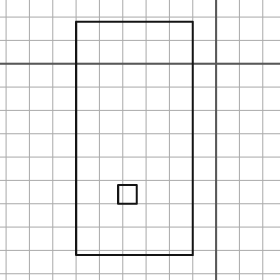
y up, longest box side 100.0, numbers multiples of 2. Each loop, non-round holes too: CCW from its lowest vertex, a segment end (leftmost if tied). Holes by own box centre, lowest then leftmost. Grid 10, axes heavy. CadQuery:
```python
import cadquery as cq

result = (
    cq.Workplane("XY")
    .moveTo(-60.0, -82.0)
    .lineTo(-10.0, -82.0)
    .lineTo(-10.0, 18.0)
    .lineTo(-60.0, 18.0)
    .close()
    .moveTo(-42.0, -60.0)
    .lineTo(-34.0, -60.0)
    .lineTo(-34.0, -52.0)
    .lineTo(-42.0, -52.0)
    .close()
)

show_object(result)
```